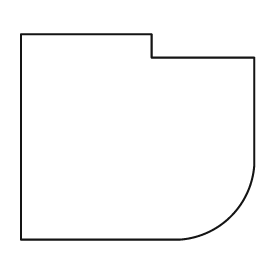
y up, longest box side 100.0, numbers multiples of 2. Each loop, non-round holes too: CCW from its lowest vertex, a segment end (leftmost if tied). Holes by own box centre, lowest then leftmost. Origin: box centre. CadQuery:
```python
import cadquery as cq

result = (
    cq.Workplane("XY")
    .moveTo(-50.0, -44.0)
    .lineTo(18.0, -44.0)
    .threePointArc((40.0, -34.0), (50.0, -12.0))
    .lineTo(50.0, 34.0)
    .lineTo(6.0, 34.0)
    .lineTo(6.0, 44.0)
    .lineTo(-50.0, 44.0)
    .close()
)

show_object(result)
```